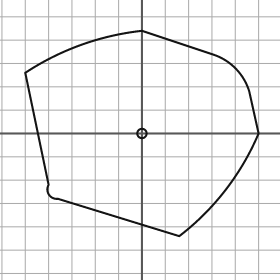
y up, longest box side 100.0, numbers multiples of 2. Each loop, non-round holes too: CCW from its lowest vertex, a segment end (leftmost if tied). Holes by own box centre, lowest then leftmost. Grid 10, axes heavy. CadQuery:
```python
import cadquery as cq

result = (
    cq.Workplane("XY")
    .moveTo(16.0, -44.0)
    .threePointArc((36.0, -24.0), (50.0, 0.0))
    .lineTo(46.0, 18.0)
    .threePointArc((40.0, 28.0), (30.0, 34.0))
    .lineTo(0.0, 44.0)
    .threePointArc((-26.0, 38.0), (-50.0, 26.0))
    .lineTo(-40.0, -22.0)
    .threePointArc((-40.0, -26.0), (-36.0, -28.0))
    .close()
    .moveTo(0.0, 0.0)
    .circle(2.0)
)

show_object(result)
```